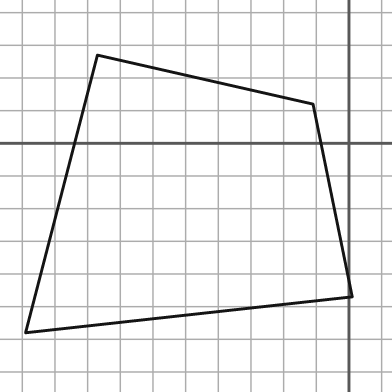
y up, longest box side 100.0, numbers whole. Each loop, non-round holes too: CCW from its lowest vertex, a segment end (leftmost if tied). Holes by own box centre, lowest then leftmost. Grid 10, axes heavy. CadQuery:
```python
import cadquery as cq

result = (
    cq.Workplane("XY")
    .moveTo(-99.0, -58.0)
    .lineTo(1.0, -47.0)
    .lineTo(-11.0, 12.0)
    .lineTo(-77.0, 27.0)
    .close()
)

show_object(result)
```